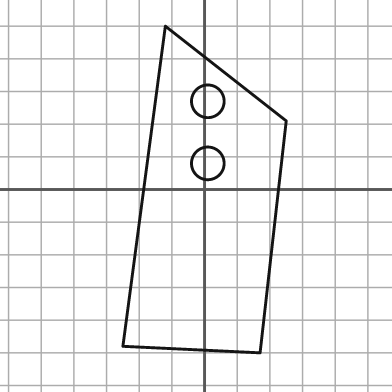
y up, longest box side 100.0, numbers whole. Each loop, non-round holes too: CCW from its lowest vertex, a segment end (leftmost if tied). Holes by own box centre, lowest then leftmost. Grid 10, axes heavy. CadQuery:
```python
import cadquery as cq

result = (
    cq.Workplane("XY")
    .moveTo(17.0, -50.0)
    .lineTo(25.0, 21.0)
    .lineTo(-12.0, 50.0)
    .lineTo(-25.0, -48.0)
    .close()
    .moveTo(1.0, 8.0)
    .circle(5.0)
    .moveTo(1.0, 27.0)
    .circle(5.0)
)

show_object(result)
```